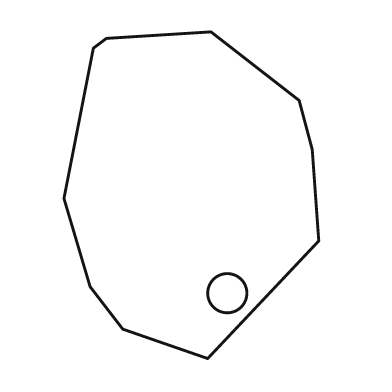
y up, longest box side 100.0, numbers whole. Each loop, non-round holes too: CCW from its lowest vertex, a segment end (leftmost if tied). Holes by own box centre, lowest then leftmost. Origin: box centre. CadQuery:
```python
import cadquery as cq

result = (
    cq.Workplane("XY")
    .moveTo(5.0, -50.0)
    .lineTo(39.0, -14.0)
    .lineTo(37.0, 14.0)
    .lineTo(33.0, 29.0)
    .lineTo(6.0, 50.0)
    .lineTo(-26.0, 48.0)
    .lineTo(-30.0, 45.0)
    .lineTo(-39.0, -1.0)
    .lineTo(-31.0, -28.0)
    .lineTo(-21.0, -41.0)
    .close()
    .moveTo(11.0, -30.0)
    .circle(6.0)
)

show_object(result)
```